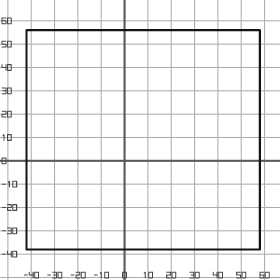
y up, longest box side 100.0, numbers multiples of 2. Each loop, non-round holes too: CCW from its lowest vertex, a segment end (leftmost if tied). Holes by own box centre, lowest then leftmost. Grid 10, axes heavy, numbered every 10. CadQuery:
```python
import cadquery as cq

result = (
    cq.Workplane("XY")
    .moveTo(-42.0, -38.0)
    .lineTo(58.0, -38.0)
    .lineTo(58.0, 56.0)
    .lineTo(-42.0, 56.0)
    .close()
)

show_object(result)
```